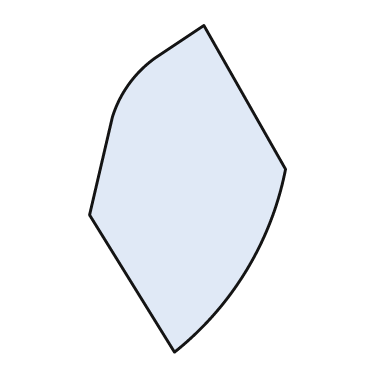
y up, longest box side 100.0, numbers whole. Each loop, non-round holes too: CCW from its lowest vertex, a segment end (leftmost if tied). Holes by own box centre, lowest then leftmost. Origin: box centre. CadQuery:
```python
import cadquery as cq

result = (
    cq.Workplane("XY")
    .moveTo(-4.0, -50.0)
    .threePointArc((18.0, -25.0), (30.0, 6.0))
    .lineTo(5.0, 50.0)
    .lineTo(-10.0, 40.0)
    .threePointArc((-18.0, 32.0), (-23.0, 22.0))
    .lineTo(-30.0, -8.0)
    .close()
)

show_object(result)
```